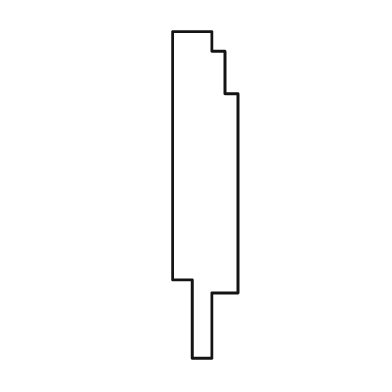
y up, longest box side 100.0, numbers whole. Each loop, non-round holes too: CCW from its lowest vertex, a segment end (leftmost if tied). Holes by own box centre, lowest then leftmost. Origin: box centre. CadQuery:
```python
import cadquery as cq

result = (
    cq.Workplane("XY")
    .moveTo(-4.0, -50.0)
    .lineTo(2.0, -50.0)
    .lineTo(2.0, -30.0)
    .lineTo(10.0, -30.0)
    .lineTo(10.0, 31.0)
    .lineTo(6.0, 31.0)
    .lineTo(6.0, 44.0)
    .lineTo(2.0, 44.0)
    .lineTo(2.0, 50.0)
    .lineTo(-10.0, 50.0)
    .lineTo(-10.0, -26.0)
    .lineTo(-4.0, -26.0)
    .close()
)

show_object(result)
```